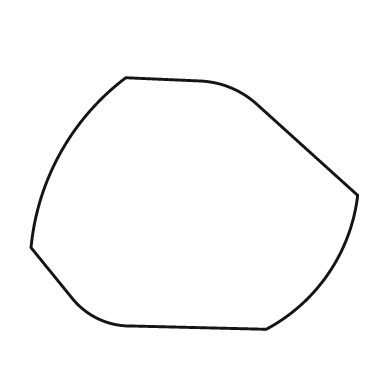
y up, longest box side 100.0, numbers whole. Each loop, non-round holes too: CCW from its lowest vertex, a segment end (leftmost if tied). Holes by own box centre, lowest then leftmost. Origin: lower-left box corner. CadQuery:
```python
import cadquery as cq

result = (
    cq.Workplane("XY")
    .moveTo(72.0, 0.0)
    .threePointArc((91.0, 17.0), (100.0, 41.0))
    .lineTo(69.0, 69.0)
    .threePointArc((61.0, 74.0), (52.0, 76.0))
    .lineTo(29.0, 77.0)
    .threePointArc((9.0, 54.0), (0.0, 25.0))
    .lineTo(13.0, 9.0)
    .threePointArc((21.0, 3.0), (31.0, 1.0))
    .close()
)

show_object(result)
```